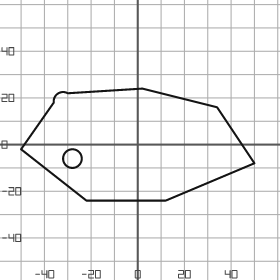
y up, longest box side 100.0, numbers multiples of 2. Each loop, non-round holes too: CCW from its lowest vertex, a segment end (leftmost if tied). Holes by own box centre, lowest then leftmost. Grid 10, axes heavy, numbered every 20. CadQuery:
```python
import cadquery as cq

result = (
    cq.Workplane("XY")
    .moveTo(-22.0, -24.0)
    .lineTo(12.0, -24.0)
    .lineTo(50.0, -8.0)
    .lineTo(34.0, 16.0)
    .lineTo(2.0, 24.0)
    .lineTo(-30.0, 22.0)
    .threePointArc((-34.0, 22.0), (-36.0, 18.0))
    .lineTo(-50.0, -2.0)
    .close()
    .moveTo(-28.0, -6.0)
    .circle(4.0)
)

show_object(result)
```